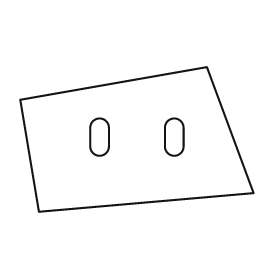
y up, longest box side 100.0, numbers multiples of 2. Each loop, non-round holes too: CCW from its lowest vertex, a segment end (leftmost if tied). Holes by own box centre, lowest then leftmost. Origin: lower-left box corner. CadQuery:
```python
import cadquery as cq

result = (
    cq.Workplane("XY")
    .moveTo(8.0, 0.0)
    .lineTo(100.0, 8.0)
    .lineTo(80.0, 62.0)
    .lineTo(0.0, 48.0)
    .close()
    .moveTo(30.0, 28.0)
    .threePointArc((34.0, 24.0), (38.0, 28.0))
    .lineTo(38.0, 36.0)
    .threePointArc((34.0, 40.0), (30.0, 36.0))
    .close()
    .moveTo(62.0, 28.0)
    .threePointArc((66.0, 24.0), (70.0, 28.0))
    .lineTo(70.0, 36.0)
    .threePointArc((66.0, 40.0), (62.0, 36.0))
    .close()
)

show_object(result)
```